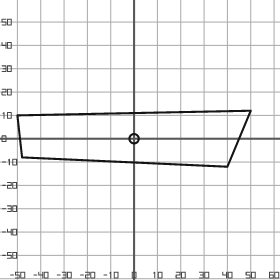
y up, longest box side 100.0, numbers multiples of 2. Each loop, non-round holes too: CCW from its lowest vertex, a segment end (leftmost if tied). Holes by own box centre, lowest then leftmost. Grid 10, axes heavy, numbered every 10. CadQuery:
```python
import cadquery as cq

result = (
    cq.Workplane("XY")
    .moveTo(40.0, -12.0)
    .lineTo(50.0, 12.0)
    .lineTo(-50.0, 10.0)
    .lineTo(-48.0, -8.0)
    .close()
    .moveTo(0.0, 0.0)
    .circle(2.0)
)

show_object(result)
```